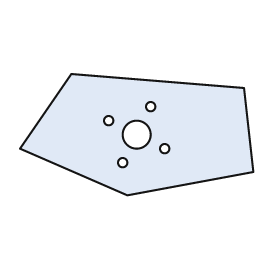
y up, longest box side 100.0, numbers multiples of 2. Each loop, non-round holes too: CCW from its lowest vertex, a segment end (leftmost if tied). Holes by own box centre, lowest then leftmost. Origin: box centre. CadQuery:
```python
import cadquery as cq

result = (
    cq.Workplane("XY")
    .moveTo(-4.0, -26.0)
    .lineTo(50.0, -16.0)
    .lineTo(46.0, 20.0)
    .lineTo(-28.0, 26.0)
    .lineTo(-50.0, -6.0)
    .close()
    .moveTo(-6.0, -12.0)
    .circle(2.0)
    .moveTo(12.0, -6.0)
    .circle(2.0)
    .moveTo(0.0, 0.0)
    .circle(6.0)
    .moveTo(-12.0, 6.0)
    .circle(2.0)
    .moveTo(6.0, 12.0)
    .circle(2.0)
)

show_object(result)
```